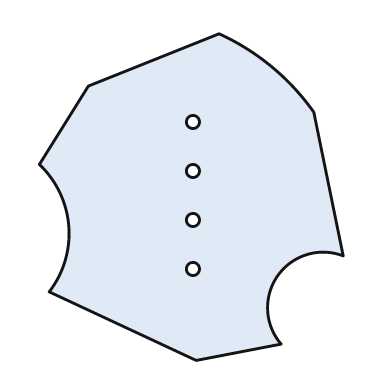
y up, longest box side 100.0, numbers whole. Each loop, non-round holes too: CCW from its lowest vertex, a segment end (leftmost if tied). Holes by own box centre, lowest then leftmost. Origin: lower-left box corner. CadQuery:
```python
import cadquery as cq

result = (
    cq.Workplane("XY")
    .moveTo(48.0, 0.0)
    .lineTo(74.0, 5.0)
    .threePointArc((73.0, 26.0), (93.0, 32.0))
    .lineTo(84.0, 76.0)
    .threePointArc((71.0, 90.0), (55.0, 100.0))
    .lineTo(15.0, 84.0)
    .lineTo(0.0, 60.0)
    .threePointArc((9.0, 41.0), (3.0, 21.0))
    .close()
    .moveTo(47.0, 28.0)
    .circle(2.0)
    .moveTo(47.0, 43.0)
    .circle(2.0)
    .moveTo(47.0, 58.0)
    .circle(2.0)
    .moveTo(47.0, 73.0)
    .circle(2.0)
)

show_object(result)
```